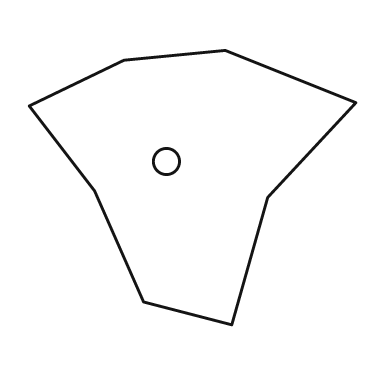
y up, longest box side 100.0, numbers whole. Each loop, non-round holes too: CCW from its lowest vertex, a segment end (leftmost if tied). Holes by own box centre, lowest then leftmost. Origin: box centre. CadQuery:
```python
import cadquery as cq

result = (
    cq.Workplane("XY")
    .moveTo(12.0, -42.0)
    .lineTo(23.0, -3.0)
    .lineTo(50.0, 26.0)
    .lineTo(10.0, 42.0)
    .lineTo(-21.0, 39.0)
    .lineTo(-50.0, 25.0)
    .lineTo(-30.0, -1.0)
    .lineTo(-15.0, -35.0)
    .close()
    .moveTo(-8.0, 8.0)
    .circle(4.0)
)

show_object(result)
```